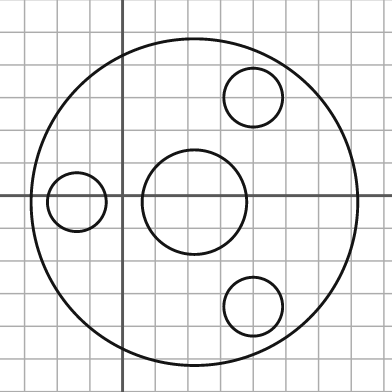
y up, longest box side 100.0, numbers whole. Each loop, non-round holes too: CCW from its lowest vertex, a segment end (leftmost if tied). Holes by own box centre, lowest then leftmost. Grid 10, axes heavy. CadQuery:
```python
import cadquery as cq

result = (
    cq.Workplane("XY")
    .moveTo(22.0, -2.0)
    .circle(50.0)
    .moveTo(40.0, -34.0)
    .circle(9.0)
    .moveTo(-14.0, -2.0)
    .circle(9.0)
    .moveTo(22.0, -2.0)
    .circle(16.0)
    .moveTo(40.0, 30.0)
    .circle(9.0)
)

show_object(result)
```